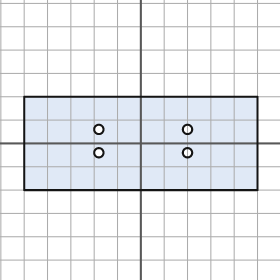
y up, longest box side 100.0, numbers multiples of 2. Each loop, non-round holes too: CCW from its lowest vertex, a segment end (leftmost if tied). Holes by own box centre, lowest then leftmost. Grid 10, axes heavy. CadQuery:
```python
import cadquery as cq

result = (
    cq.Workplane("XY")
    .moveTo(-50.0, -20.0)
    .lineTo(50.0, -20.0)
    .lineTo(50.0, 20.0)
    .lineTo(-50.0, 20.0)
    .close()
    .moveTo(-18.0, -4.0)
    .circle(2.0)
    .moveTo(20.0, -4.0)
    .circle(2.0)
    .moveTo(-18.0, 6.0)
    .circle(2.0)
    .moveTo(20.0, 6.0)
    .circle(2.0)
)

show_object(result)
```